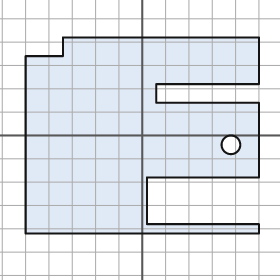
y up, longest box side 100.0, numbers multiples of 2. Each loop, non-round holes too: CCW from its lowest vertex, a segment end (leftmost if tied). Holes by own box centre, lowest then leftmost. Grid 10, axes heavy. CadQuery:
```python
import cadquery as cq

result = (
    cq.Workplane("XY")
    .moveTo(-50.0, -42.0)
    .lineTo(50.0, -42.0)
    .lineTo(50.0, -38.0)
    .lineTo(2.0, -38.0)
    .lineTo(2.0, -18.0)
    .lineTo(50.0, -18.0)
    .lineTo(50.0, 14.0)
    .lineTo(6.0, 14.0)
    .lineTo(6.0, 22.0)
    .lineTo(50.0, 22.0)
    .lineTo(50.0, 42.0)
    .lineTo(-34.0, 42.0)
    .lineTo(-34.0, 34.0)
    .lineTo(-50.0, 34.0)
    .close()
    .moveTo(38.0, -4.0)
    .circle(4.0)
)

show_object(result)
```